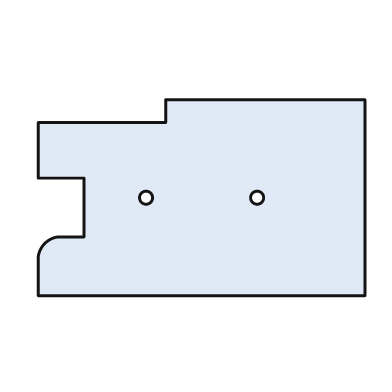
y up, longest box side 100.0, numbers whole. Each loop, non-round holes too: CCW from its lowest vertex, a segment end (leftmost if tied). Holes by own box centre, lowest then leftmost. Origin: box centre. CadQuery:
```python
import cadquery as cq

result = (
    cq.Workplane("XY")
    .moveTo(-50.0, -30.0)
    .lineTo(50.0, -30.0)
    .lineTo(50.0, 30.0)
    .lineTo(-11.0, 30.0)
    .lineTo(-11.0, 23.0)
    .lineTo(-50.0, 23.0)
    .lineTo(-50.0, 6.0)
    .lineTo(-36.0, 6.0)
    .lineTo(-36.0, -12.0)
    .lineTo(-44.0, -12.0)
    .threePointArc((-48.0, -14.0), (-50.0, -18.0))
    .close()
    .moveTo(-17.0, 0.0)
    .circle(2.0)
    .moveTo(17.0, 0.0)
    .circle(2.0)
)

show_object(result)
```